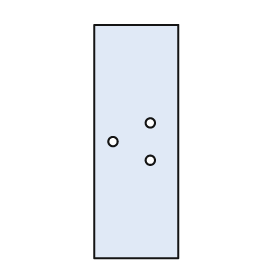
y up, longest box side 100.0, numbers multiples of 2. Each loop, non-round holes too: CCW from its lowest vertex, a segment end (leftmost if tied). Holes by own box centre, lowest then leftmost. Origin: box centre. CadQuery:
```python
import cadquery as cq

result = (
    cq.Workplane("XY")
    .moveTo(-18.0, -50.0)
    .lineTo(18.0, -50.0)
    .lineTo(18.0, 50.0)
    .lineTo(-18.0, 50.0)
    .close()
    .moveTo(6.0, -8.0)
    .circle(2.0)
    .moveTo(-10.0, 0.0)
    .circle(2.0)
    .moveTo(6.0, 8.0)
    .circle(2.0)
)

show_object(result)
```